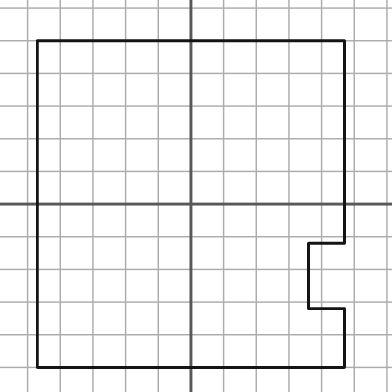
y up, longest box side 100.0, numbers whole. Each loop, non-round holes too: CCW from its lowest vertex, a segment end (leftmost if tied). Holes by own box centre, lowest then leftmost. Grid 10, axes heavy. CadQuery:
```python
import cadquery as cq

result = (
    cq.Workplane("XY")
    .moveTo(-47.0, -50.0)
    .lineTo(47.0, -50.0)
    .lineTo(47.0, -32.0)
    .lineTo(36.0, -32.0)
    .lineTo(36.0, -12.0)
    .lineTo(47.0, -12.0)
    .lineTo(47.0, 50.0)
    .lineTo(-47.0, 50.0)
    .close()
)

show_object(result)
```